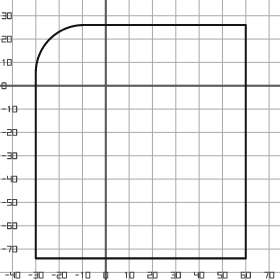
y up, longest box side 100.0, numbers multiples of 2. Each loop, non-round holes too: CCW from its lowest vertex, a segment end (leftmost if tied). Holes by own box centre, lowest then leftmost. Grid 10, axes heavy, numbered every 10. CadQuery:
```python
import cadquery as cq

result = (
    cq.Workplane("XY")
    .moveTo(-30.0, -74.0)
    .lineTo(60.0, -74.0)
    .lineTo(60.0, 26.0)
    .lineTo(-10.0, 26.0)
    .threePointArc((-24.0, 20.0), (-30.0, 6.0))
    .close()
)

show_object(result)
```